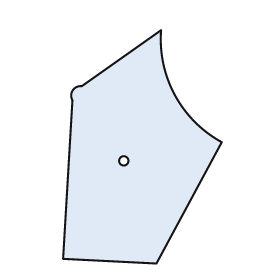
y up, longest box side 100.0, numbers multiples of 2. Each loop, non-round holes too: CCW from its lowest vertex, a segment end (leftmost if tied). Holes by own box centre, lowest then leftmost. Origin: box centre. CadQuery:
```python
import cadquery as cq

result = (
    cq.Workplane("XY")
    .moveTo(6.0, -50.0)
    .lineTo(34.0, 2.0)
    .threePointArc((14.0, 22.0), (8.0, 50.0))
    .lineTo(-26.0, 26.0)
    .threePointArc((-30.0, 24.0), (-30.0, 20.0))
    .lineTo(-34.0, -48.0)
    .close()
    .moveTo(-8.0, -6.0)
    .circle(2.0)
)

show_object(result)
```